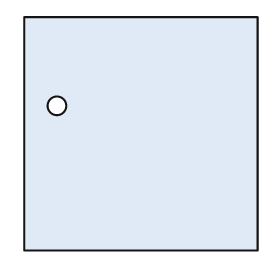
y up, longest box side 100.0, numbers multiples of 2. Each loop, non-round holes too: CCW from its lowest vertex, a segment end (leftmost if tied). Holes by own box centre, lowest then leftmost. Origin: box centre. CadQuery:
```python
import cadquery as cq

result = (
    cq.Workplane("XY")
    .moveTo(-50.0, -50.0)
    .lineTo(50.0, -50.0)
    .lineTo(50.0, 50.0)
    .lineTo(-50.0, 50.0)
    .close()
    .moveTo(-36.0, 12.0)
    .circle(4.0)
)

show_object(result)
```